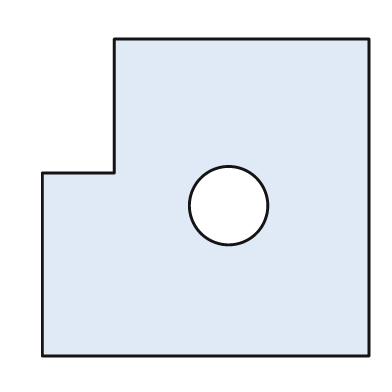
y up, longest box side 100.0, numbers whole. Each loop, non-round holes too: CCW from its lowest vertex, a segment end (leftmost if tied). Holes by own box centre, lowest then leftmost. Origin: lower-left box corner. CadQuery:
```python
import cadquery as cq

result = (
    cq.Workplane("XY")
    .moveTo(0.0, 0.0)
    .lineTo(100.0, 0.0)
    .lineTo(100.0, 97.0)
    .lineTo(22.0, 97.0)
    .lineTo(22.0, 56.0)
    .lineTo(0.0, 56.0)
    .close()
    .moveTo(57.0, 46.0)
    .circle(12.0)
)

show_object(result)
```